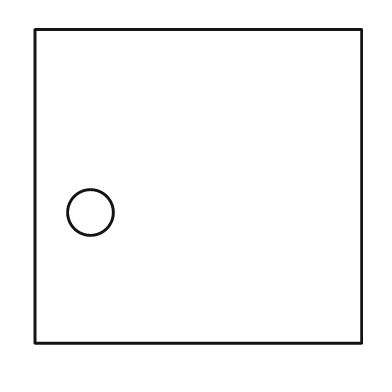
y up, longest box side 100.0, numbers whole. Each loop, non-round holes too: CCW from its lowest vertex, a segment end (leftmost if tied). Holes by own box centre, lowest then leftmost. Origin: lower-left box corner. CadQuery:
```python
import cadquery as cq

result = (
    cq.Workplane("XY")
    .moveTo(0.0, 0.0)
    .lineTo(100.0, 0.0)
    .lineTo(100.0, 96.0)
    .lineTo(0.0, 96.0)
    .close()
    .moveTo(17.0, 40.0)
    .circle(7.0)
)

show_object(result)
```